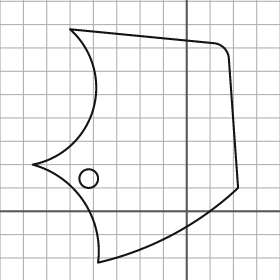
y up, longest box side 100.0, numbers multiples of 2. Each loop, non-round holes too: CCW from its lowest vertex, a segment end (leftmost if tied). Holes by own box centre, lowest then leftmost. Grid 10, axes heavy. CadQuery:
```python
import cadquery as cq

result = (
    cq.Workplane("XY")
    .moveTo(-38.0, -22.0)
    .threePointArc((-6.0, -10.0), (22.0, 10.0))
    .lineTo(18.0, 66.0)
    .threePointArc((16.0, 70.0), (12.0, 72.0))
    .lineTo(-50.0, 78.0)
    .threePointArc((-40.0, 44.0), (-66.0, 20.0))
    .threePointArc((-44.0, 4.0), (-38.0, -22.0))
    .close()
    .moveTo(-42.0, 14.0)
    .circle(4.0)
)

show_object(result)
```